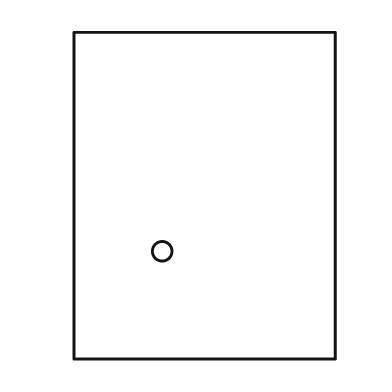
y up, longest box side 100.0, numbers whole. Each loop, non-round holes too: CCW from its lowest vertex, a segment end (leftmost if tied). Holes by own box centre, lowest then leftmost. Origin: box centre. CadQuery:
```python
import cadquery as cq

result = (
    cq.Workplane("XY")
    .moveTo(-40.0, -50.0)
    .lineTo(40.0, -50.0)
    .lineTo(40.0, 50.0)
    .lineTo(-40.0, 50.0)
    .close()
    .moveTo(-13.0, -17.0)
    .circle(3.0)
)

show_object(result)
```